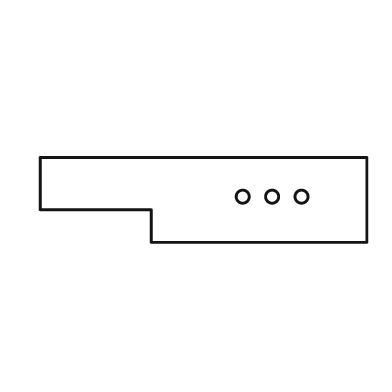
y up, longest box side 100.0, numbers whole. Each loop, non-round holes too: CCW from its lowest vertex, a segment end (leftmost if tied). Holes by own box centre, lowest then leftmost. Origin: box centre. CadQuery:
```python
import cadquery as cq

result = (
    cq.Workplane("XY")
    .moveTo(-16.0, -13.0)
    .lineTo(50.0, -13.0)
    .lineTo(50.0, 13.0)
    .lineTo(-50.0, 13.0)
    .lineTo(-50.0, -3.0)
    .lineTo(-16.0, -3.0)
    .close()
    .moveTo(12.0, 1.0)
    .circle(2.0)
    .moveTo(21.0, 1.0)
    .circle(2.0)
    .moveTo(30.0, 1.0)
    .circle(2.0)
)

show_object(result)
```